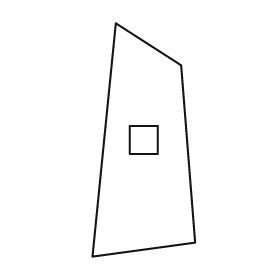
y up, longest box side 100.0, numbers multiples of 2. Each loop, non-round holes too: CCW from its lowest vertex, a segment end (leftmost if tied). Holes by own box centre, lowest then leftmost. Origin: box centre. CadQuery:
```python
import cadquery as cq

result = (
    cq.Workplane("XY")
    .moveTo(-22.0, -50.0)
    .lineTo(22.0, -44.0)
    .lineTo(16.0, 32.0)
    .lineTo(-12.0, 50.0)
    .close()
    .moveTo(-6.0, -6.0)
    .lineTo(6.0, -6.0)
    .lineTo(6.0, 6.0)
    .lineTo(-6.0, 6.0)
    .close()
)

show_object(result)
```